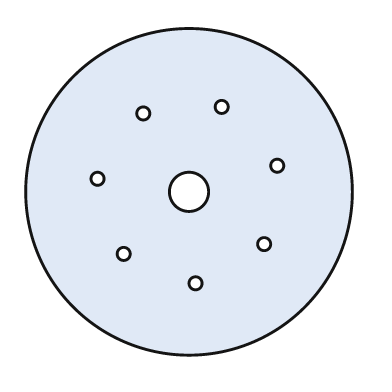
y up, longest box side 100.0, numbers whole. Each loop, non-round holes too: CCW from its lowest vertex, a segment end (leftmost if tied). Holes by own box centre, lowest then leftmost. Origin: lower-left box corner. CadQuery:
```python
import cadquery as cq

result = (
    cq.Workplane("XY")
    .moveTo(50.0, 50.0)
    .circle(50.0)
    .moveTo(52.0, 22.0)
    .circle(2.0)
    .moveTo(30.0, 31.0)
    .circle(2.0)
    .moveTo(73.0, 34.0)
    .circle(2.0)
    .moveTo(50.0, 50.0)
    .circle(6.0)
    .moveTo(22.0, 54.0)
    .circle(2.0)
    .moveTo(77.0, 58.0)
    .circle(2.0)
    .moveTo(36.0, 74.0)
    .circle(2.0)
    .moveTo(60.0, 76.0)
    .circle(2.0)
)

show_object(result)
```